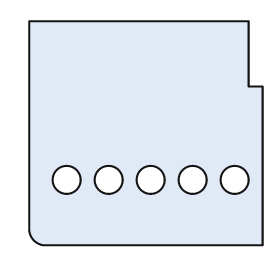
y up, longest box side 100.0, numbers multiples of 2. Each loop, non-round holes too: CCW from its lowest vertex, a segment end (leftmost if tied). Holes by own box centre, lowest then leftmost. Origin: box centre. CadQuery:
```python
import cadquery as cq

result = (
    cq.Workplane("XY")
    .moveTo(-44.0, -48.0)
    .lineTo(50.0, -48.0)
    .lineTo(50.0, 20.0)
    .lineTo(44.0, 20.0)
    .lineTo(44.0, 48.0)
    .lineTo(-50.0, 48.0)
    .lineTo(-50.0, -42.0)
    .threePointArc((-48.0, -46.0), (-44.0, -48.0))
    .close()
    .moveTo(-34.0, -20.0)
    .circle(6.0)
    .moveTo(-16.0, -20.0)
    .circle(6.0)
    .moveTo(2.0, -20.0)
    .circle(6.0)
    .moveTo(20.0, -20.0)
    .circle(6.0)
    .moveTo(38.0, -20.0)
    .circle(6.0)
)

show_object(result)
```